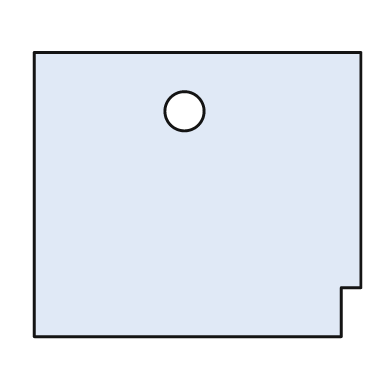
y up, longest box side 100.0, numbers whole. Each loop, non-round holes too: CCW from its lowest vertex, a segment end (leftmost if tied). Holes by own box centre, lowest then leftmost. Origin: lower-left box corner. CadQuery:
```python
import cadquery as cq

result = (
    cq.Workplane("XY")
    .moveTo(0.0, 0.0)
    .lineTo(94.0, 0.0)
    .lineTo(94.0, 15.0)
    .lineTo(100.0, 15.0)
    .lineTo(100.0, 87.0)
    .lineTo(0.0, 87.0)
    .close()
    .moveTo(46.0, 69.0)
    .circle(6.0)
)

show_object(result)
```